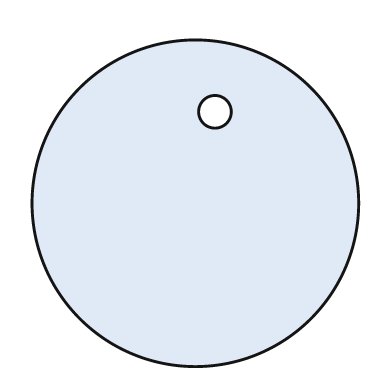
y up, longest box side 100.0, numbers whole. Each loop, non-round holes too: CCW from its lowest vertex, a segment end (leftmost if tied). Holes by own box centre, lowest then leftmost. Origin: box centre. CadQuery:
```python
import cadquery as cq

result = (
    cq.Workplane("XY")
    .moveTo(0.0, 0.0)
    .circle(50.0)
    .moveTo(6.0, 28.0)
    .circle(5.0)
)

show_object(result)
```